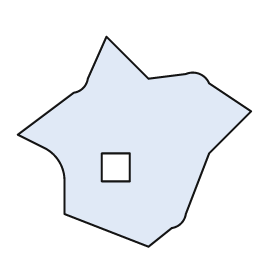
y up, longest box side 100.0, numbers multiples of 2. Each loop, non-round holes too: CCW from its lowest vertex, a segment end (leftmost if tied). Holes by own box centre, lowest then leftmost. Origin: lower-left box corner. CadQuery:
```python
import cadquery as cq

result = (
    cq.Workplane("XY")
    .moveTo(56.0, 0.0)
    .lineTo(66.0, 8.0)
    .threePointArc((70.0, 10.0), (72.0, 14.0))
    .lineTo(82.0, 40.0)
    .lineTo(100.0, 58.0)
    .lineTo(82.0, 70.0)
    .threePointArc((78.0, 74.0), (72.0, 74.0))
    .lineTo(56.0, 72.0)
    .lineTo(38.0, 90.0)
    .lineTo(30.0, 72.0)
    .threePointArc((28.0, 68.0), (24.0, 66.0))
    .lineTo(0.0, 48.0)
    .lineTo(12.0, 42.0)
    .threePointArc((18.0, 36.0), (20.0, 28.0))
    .lineTo(20.0, 14.0)
    .close()
    .moveTo(36.0, 28.0)
    .lineTo(48.0, 28.0)
    .lineTo(48.0, 40.0)
    .lineTo(36.0, 40.0)
    .close()
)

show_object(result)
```